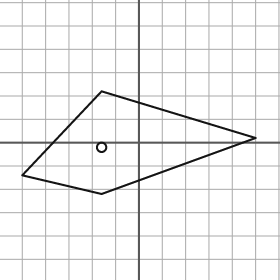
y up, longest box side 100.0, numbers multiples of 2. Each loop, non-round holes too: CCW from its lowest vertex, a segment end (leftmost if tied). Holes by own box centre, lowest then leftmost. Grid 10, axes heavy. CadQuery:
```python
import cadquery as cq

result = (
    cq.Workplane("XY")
    .moveTo(-16.0, -22.0)
    .lineTo(50.0, 2.0)
    .lineTo(-16.0, 22.0)
    .lineTo(-50.0, -14.0)
    .close()
    .moveTo(-16.0, -2.0)
    .circle(2.0)
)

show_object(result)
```